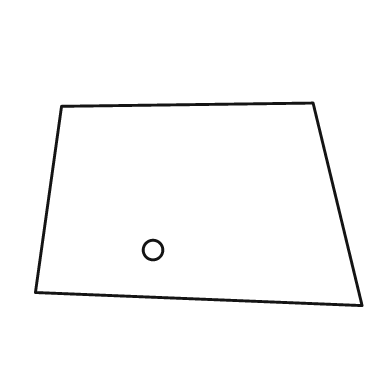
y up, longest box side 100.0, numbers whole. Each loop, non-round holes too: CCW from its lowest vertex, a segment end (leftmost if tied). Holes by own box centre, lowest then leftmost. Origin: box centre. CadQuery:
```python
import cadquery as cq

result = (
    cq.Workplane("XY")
    .moveTo(50.0, -31.0)
    .lineTo(35.0, 31.0)
    .lineTo(-42.0, 30.0)
    .lineTo(-50.0, -27.0)
    .close()
    .moveTo(-14.0, -14.0)
    .circle(3.0)
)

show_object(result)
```